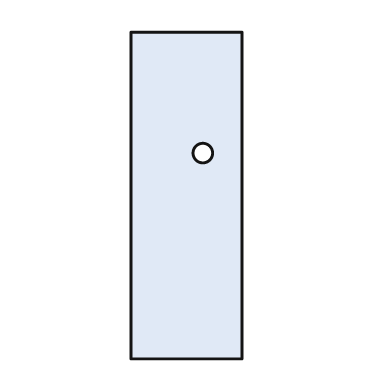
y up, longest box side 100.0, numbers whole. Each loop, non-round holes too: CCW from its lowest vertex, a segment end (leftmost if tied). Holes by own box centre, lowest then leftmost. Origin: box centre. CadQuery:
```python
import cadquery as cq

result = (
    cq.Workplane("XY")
    .moveTo(-17.0, -50.0)
    .lineTo(17.0, -50.0)
    .lineTo(17.0, 50.0)
    .lineTo(-17.0, 50.0)
    .close()
    .moveTo(5.0, 13.0)
    .circle(3.0)
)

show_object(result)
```